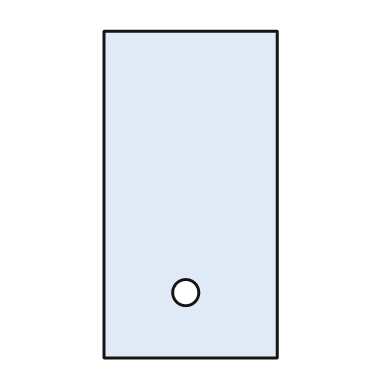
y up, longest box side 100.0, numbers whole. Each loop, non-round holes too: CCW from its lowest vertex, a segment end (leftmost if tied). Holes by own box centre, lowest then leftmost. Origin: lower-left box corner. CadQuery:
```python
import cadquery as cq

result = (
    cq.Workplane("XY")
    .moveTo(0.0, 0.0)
    .lineTo(53.0, 0.0)
    .lineTo(53.0, 100.0)
    .lineTo(0.0, 100.0)
    .close()
    .moveTo(25.0, 20.0)
    .circle(4.0)
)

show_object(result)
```